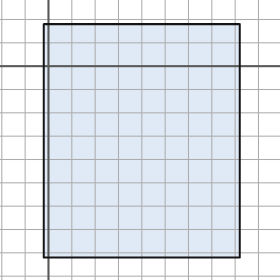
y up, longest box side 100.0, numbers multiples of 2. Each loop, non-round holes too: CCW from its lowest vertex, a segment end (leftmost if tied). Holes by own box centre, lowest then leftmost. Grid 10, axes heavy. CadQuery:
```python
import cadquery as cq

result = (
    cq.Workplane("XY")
    .moveTo(-2.0, -82.0)
    .lineTo(82.0, -82.0)
    .lineTo(82.0, 18.0)
    .lineTo(-2.0, 18.0)
    .close()
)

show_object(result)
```